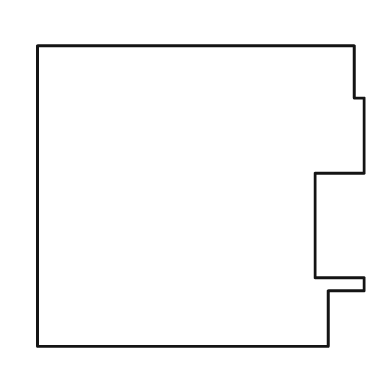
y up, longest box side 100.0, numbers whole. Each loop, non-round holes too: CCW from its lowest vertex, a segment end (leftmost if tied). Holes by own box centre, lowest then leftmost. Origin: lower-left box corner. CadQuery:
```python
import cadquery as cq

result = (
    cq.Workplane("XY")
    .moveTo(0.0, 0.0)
    .lineTo(89.0, 0.0)
    .lineTo(89.0, 17.0)
    .lineTo(100.0, 17.0)
    .lineTo(100.0, 21.0)
    .lineTo(85.0, 21.0)
    .lineTo(85.0, 53.0)
    .lineTo(100.0, 53.0)
    .lineTo(100.0, 76.0)
    .lineTo(97.0, 76.0)
    .lineTo(97.0, 92.0)
    .lineTo(0.0, 92.0)
    .close()
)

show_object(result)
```